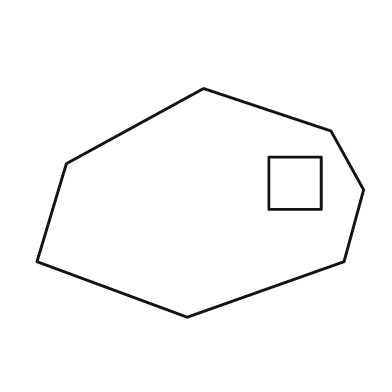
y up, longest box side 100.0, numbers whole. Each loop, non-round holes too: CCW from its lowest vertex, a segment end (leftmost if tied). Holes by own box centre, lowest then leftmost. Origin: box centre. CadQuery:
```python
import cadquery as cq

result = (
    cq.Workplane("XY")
    .moveTo(-4.0, -35.0)
    .lineTo(44.0, -18.0)
    .lineTo(50.0, 4.0)
    .lineTo(40.0, 22.0)
    .lineTo(1.0, 35.0)
    .lineTo(-41.0, 12.0)
    .lineTo(-50.0, -18.0)
    .close()
    .moveTo(21.0, -2.0)
    .lineTo(37.0, -2.0)
    .lineTo(37.0, 14.0)
    .lineTo(21.0, 14.0)
    .close()
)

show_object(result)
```